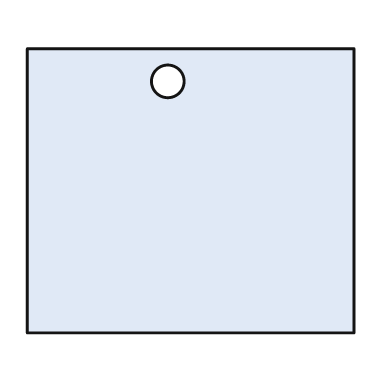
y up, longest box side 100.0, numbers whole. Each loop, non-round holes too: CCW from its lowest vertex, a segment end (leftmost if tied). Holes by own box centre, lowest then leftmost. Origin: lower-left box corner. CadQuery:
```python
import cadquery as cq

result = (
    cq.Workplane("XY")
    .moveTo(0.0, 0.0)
    .lineTo(100.0, 0.0)
    .lineTo(100.0, 87.0)
    .lineTo(0.0, 87.0)
    .close()
    .moveTo(43.0, 77.0)
    .circle(5.0)
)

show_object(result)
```